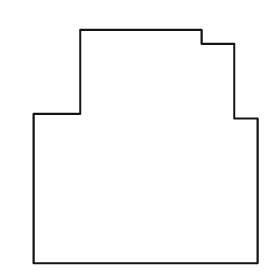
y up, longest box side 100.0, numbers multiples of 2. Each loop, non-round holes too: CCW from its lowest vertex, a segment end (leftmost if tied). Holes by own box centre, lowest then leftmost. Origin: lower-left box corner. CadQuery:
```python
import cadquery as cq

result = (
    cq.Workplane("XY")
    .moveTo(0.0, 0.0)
    .lineTo(96.0, 0.0)
    .lineTo(96.0, 62.0)
    .lineTo(86.0, 62.0)
    .lineTo(86.0, 94.0)
    .lineTo(72.0, 94.0)
    .lineTo(72.0, 100.0)
    .lineTo(20.0, 100.0)
    .lineTo(20.0, 64.0)
    .lineTo(0.0, 64.0)
    .close()
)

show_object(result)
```